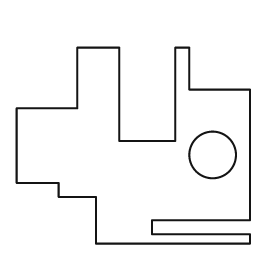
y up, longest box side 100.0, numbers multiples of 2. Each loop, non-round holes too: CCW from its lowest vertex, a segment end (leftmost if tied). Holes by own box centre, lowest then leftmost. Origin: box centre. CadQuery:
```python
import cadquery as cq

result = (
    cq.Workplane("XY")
    .moveTo(-16.0, -42.0)
    .lineTo(50.0, -42.0)
    .lineTo(50.0, -38.0)
    .lineTo(8.0, -38.0)
    .lineTo(8.0, -32.0)
    .lineTo(50.0, -32.0)
    .lineTo(50.0, 24.0)
    .lineTo(24.0, 24.0)
    .lineTo(24.0, 42.0)
    .lineTo(18.0, 42.0)
    .lineTo(18.0, 2.0)
    .lineTo(-6.0, 2.0)
    .lineTo(-6.0, 42.0)
    .lineTo(-24.0, 42.0)
    .lineTo(-24.0, 16.0)
    .lineTo(-50.0, 16.0)
    .lineTo(-50.0, -16.0)
    .lineTo(-32.0, -16.0)
    .lineTo(-32.0, -22.0)
    .lineTo(-16.0, -22.0)
    .close()
    .moveTo(34.0, -4.0)
    .circle(10.0)
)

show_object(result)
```